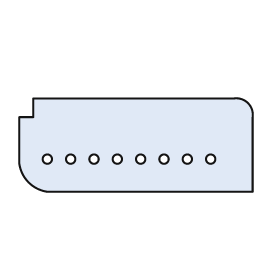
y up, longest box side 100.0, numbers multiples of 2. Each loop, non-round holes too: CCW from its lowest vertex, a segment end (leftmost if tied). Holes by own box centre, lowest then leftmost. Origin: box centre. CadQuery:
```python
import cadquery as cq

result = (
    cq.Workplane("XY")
    .moveTo(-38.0, -20.0)
    .lineTo(50.0, -20.0)
    .lineTo(50.0, 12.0)
    .threePointArc((48.0, 18.0), (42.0, 20.0))
    .lineTo(-44.0, 20.0)
    .lineTo(-44.0, 12.0)
    .lineTo(-50.0, 12.0)
    .lineTo(-50.0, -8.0)
    .threePointArc((-46.0, -16.0), (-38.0, -20.0))
    .close()
    .moveTo(-38.0, -6.0)
    .circle(2.0)
    .moveTo(-28.0, -6.0)
    .circle(2.0)
    .moveTo(-18.0, -6.0)
    .circle(2.0)
    .moveTo(-8.0, -6.0)
    .circle(2.0)
    .moveTo(2.0, -6.0)
    .circle(2.0)
    .moveTo(12.0, -6.0)
    .circle(2.0)
    .moveTo(22.0, -6.0)
    .circle(2.0)
    .moveTo(32.0, -6.0)
    .circle(2.0)
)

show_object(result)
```